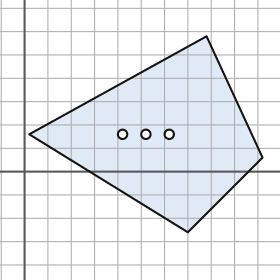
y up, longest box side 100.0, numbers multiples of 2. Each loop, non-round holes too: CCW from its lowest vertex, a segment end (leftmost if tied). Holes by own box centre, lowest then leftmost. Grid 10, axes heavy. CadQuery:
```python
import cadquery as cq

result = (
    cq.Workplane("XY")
    .moveTo(70.0, -26.0)
    .lineTo(102.0, 6.0)
    .lineTo(78.0, 58.0)
    .lineTo(2.0, 16.0)
    .close()
    .moveTo(42.0, 16.0)
    .circle(2.0)
    .moveTo(52.0, 16.0)
    .circle(2.0)
    .moveTo(62.0, 16.0)
    .circle(2.0)
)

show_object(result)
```